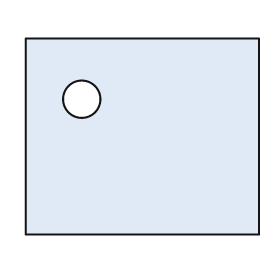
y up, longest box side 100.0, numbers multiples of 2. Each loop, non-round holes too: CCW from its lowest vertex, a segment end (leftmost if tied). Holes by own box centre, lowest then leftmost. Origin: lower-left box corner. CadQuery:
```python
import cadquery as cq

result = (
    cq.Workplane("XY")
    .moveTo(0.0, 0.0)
    .lineTo(100.0, 0.0)
    .lineTo(100.0, 84.0)
    .lineTo(0.0, 84.0)
    .close()
    .moveTo(24.0, 58.0)
    .circle(8.0)
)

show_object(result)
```